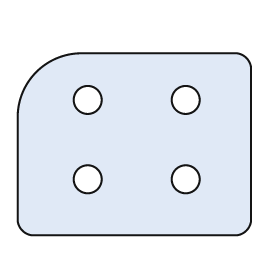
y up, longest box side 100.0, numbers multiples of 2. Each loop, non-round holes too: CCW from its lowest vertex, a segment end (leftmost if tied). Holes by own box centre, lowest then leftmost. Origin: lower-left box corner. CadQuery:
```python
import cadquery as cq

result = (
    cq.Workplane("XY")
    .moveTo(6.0, 0.0)
    .lineTo(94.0, 0.0)
    .threePointArc((98.0, 2.0), (100.0, 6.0))
    .lineTo(100.0, 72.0)
    .threePointArc((98.0, 76.0), (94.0, 78.0))
    .lineTo(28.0, 78.0)
    .threePointArc((8.0, 70.0), (0.0, 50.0))
    .lineTo(0.0, 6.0)
    .threePointArc((2.0, 2.0), (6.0, 0.0))
    .close()
    .moveTo(30.0, 24.0)
    .circle(6.0)
    .moveTo(72.0, 24.0)
    .circle(6.0)
    .moveTo(30.0, 58.0)
    .circle(6.0)
    .moveTo(72.0, 58.0)
    .circle(6.0)
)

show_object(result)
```